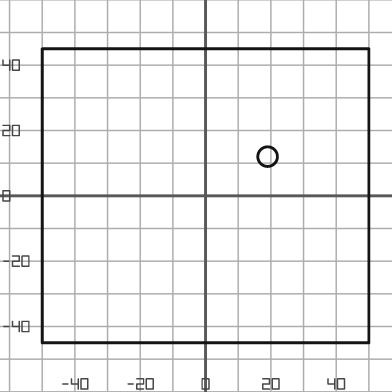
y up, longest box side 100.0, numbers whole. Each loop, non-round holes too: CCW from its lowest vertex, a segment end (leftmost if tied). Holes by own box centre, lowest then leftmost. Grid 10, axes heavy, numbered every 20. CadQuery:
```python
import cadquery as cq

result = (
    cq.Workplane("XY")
    .moveTo(-50.0, -45.0)
    .lineTo(50.0, -45.0)
    .lineTo(50.0, 45.0)
    .lineTo(-50.0, 45.0)
    .close()
    .moveTo(19.0, 12.0)
    .circle(3.0)
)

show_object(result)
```